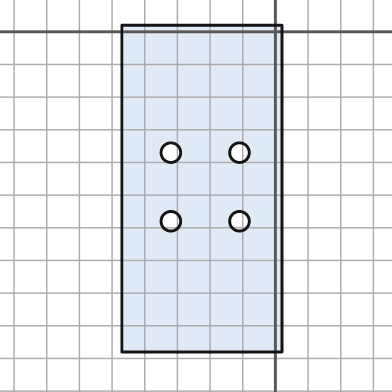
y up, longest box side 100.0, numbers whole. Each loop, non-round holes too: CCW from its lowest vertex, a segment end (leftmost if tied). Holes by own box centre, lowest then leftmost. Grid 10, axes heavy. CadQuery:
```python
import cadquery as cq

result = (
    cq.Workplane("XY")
    .moveTo(-47.0, -98.0)
    .lineTo(2.0, -98.0)
    .lineTo(2.0, 2.0)
    .lineTo(-47.0, 2.0)
    .close()
    .moveTo(-32.0, -58.0)
    .circle(3.0)
    .moveTo(-11.0, -58.0)
    .circle(3.0)
    .moveTo(-32.0, -37.0)
    .circle(3.0)
    .moveTo(-11.0, -37.0)
    .circle(3.0)
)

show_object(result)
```